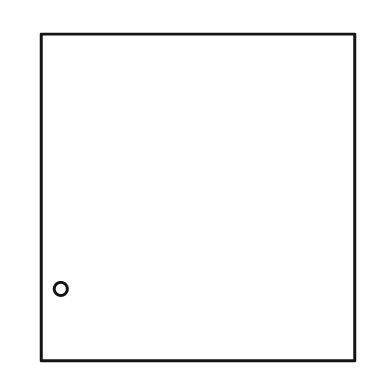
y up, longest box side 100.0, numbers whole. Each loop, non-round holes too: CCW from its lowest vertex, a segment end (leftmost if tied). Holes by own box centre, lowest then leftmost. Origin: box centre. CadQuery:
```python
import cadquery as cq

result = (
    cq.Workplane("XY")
    .moveTo(-48.0, -50.0)
    .lineTo(48.0, -50.0)
    .lineTo(48.0, 50.0)
    .lineTo(-48.0, 50.0)
    .close()
    .moveTo(-42.0, -28.0)
    .circle(2.0)
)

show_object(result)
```